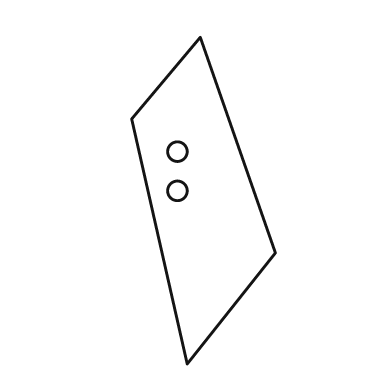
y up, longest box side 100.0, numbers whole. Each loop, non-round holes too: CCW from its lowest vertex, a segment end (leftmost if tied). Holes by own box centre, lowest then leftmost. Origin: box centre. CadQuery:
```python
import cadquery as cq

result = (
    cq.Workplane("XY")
    .moveTo(-5.0, -50.0)
    .lineTo(22.0, -16.0)
    .lineTo(-1.0, 50.0)
    .lineTo(-22.0, 25.0)
    .close()
    .moveTo(-8.0, 3.0)
    .circle(3.0)
    .moveTo(-8.0, 15.0)
    .circle(3.0)
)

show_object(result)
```